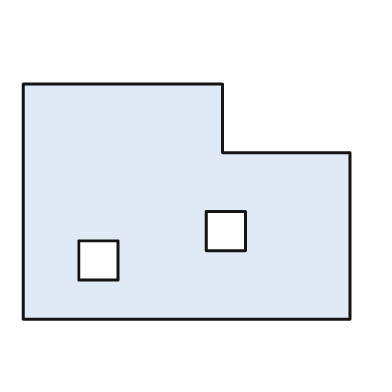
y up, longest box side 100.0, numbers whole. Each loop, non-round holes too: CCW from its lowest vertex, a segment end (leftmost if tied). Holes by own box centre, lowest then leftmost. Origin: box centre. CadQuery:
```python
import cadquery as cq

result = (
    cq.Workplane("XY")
    .moveTo(-50.0, -36.0)
    .lineTo(50.0, -36.0)
    .lineTo(50.0, 15.0)
    .lineTo(11.0, 15.0)
    .lineTo(11.0, 36.0)
    .lineTo(-50.0, 36.0)
    .close()
    .moveTo(-33.0, -24.0)
    .lineTo(-21.0, -24.0)
    .lineTo(-21.0, -12.0)
    .lineTo(-33.0, -12.0)
    .close()
    .moveTo(6.0, -15.0)
    .lineTo(18.0, -15.0)
    .lineTo(18.0, -3.0)
    .lineTo(6.0, -3.0)
    .close()
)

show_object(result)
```